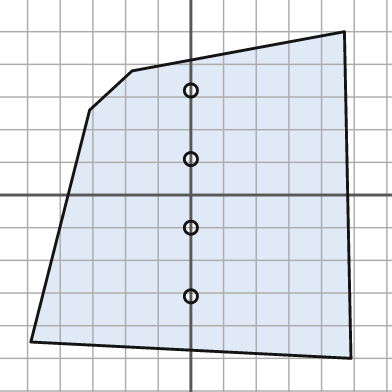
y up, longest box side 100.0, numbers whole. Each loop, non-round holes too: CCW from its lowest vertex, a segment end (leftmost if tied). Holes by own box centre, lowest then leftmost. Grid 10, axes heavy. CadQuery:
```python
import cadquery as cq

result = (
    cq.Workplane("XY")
    .moveTo(49.0, -50.0)
    .lineTo(47.0, 50.0)
    .lineTo(-18.0, 38.0)
    .lineTo(-31.0, 26.0)
    .lineTo(-49.0, -45.0)
    .close()
    .moveTo(0.0, -31.0)
    .circle(2.0)
    .moveTo(0.0, -10.0)
    .circle(2.0)
    .moveTo(0.0, 11.0)
    .circle(2.0)
    .moveTo(0.0, 32.0)
    .circle(2.0)
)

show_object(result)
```